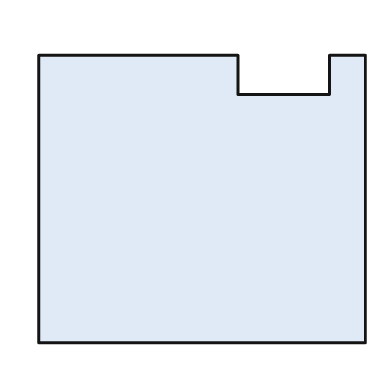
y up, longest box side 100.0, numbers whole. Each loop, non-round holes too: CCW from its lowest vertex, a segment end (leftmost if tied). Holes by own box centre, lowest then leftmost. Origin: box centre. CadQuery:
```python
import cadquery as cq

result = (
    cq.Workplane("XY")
    .moveTo(-50.0, -44.0)
    .lineTo(50.0, -44.0)
    .lineTo(50.0, 44.0)
    .lineTo(39.0, 44.0)
    .lineTo(39.0, 32.0)
    .lineTo(11.0, 32.0)
    .lineTo(11.0, 44.0)
    .lineTo(-50.0, 44.0)
    .close()
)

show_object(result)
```